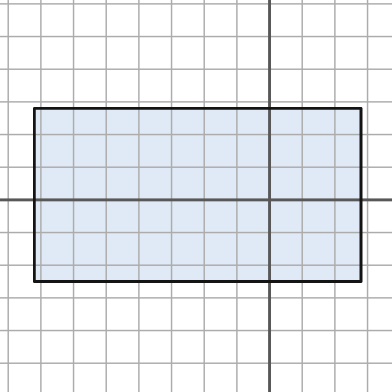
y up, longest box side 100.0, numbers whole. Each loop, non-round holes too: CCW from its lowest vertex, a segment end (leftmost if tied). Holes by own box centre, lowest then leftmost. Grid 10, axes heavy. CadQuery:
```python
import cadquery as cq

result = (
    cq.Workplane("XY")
    .moveTo(-72.0, -25.0)
    .lineTo(28.0, -25.0)
    .lineTo(28.0, 28.0)
    .lineTo(-72.0, 28.0)
    .close()
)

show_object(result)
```